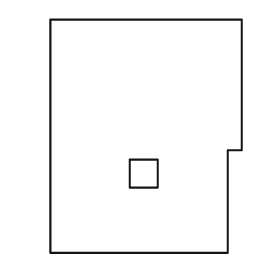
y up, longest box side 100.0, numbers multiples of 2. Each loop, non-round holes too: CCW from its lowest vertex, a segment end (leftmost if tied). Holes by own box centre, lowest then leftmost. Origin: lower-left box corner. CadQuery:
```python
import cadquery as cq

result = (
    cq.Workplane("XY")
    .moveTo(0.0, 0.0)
    .lineTo(76.0, 0.0)
    .lineTo(76.0, 44.0)
    .lineTo(82.0, 44.0)
    .lineTo(82.0, 100.0)
    .lineTo(0.0, 100.0)
    .close()
    .moveTo(34.0, 28.0)
    .lineTo(46.0, 28.0)
    .lineTo(46.0, 40.0)
    .lineTo(34.0, 40.0)
    .close()
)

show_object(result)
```